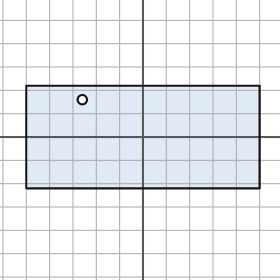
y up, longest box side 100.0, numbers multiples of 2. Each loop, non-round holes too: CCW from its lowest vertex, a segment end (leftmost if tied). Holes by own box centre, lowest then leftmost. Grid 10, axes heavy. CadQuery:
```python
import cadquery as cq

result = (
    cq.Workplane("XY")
    .moveTo(-50.0, -22.0)
    .lineTo(50.0, -22.0)
    .lineTo(50.0, 22.0)
    .lineTo(-50.0, 22.0)
    .close()
    .moveTo(-26.0, 16.0)
    .circle(2.0)
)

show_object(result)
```